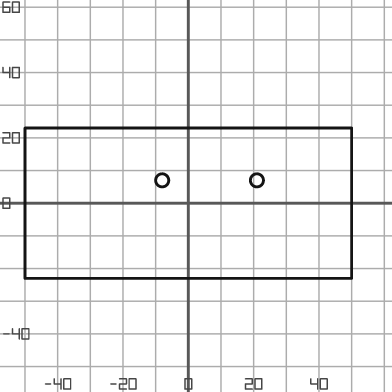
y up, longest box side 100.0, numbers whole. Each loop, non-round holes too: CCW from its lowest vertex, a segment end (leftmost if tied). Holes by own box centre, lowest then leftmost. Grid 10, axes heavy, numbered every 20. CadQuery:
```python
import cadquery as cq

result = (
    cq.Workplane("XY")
    .moveTo(-50.0, -23.0)
    .lineTo(50.0, -23.0)
    .lineTo(50.0, 23.0)
    .lineTo(-50.0, 23.0)
    .close()
    .moveTo(-8.0, 7.0)
    .circle(2.0)
    .moveTo(21.0, 7.0)
    .circle(2.0)
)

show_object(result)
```